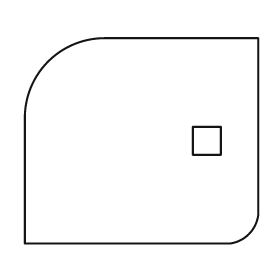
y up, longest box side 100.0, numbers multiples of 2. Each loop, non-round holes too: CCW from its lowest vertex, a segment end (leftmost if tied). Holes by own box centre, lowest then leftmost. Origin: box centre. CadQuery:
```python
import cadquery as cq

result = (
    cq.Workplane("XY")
    .moveTo(-50.0, -44.0)
    .lineTo(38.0, -44.0)
    .threePointArc((46.0, -40.0), (50.0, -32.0))
    .lineTo(50.0, 44.0)
    .lineTo(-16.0, 44.0)
    .threePointArc((-40.0, 34.0), (-50.0, 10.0))
    .close()
    .moveTo(22.0, -6.0)
    .lineTo(34.0, -6.0)
    .lineTo(34.0, 6.0)
    .lineTo(22.0, 6.0)
    .close()
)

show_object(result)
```